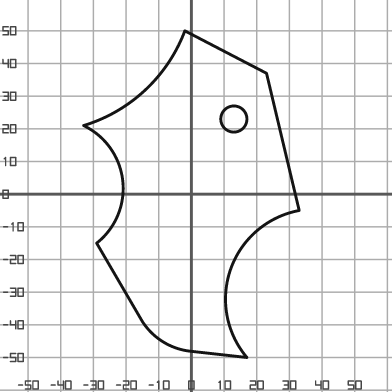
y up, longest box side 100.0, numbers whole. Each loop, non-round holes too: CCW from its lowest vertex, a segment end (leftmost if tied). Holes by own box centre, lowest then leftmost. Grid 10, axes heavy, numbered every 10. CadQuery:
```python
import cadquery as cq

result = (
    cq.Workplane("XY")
    .moveTo(17.0, -50.0)
    .threePointArc((12.0, -23.0), (33.0, -5.0))
    .lineTo(23.0, 37.0)
    .lineTo(-2.0, 50.0)
    .threePointArc((-14.0, 32.0), (-33.0, 21.0))
    .threePointArc((-21.0, 4.0), (-29.0, -15.0))
    .lineTo(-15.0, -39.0)
    .threePointArc((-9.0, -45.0), (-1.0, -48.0))
    .close()
    .moveTo(13.0, 23.0)
    .circle(4.0)
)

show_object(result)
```